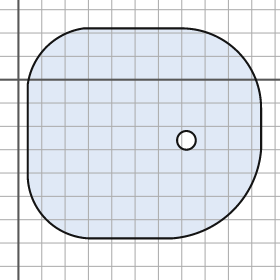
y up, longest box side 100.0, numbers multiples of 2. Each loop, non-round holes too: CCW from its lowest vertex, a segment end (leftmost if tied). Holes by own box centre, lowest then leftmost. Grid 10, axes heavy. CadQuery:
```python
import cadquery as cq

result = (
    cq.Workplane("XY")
    .moveTo(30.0, -68.0)
    .lineTo(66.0, -68.0)
    .threePointArc((92.0, -56.0), (104.0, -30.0))
    .lineTo(104.0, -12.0)
    .threePointArc((94.0, 12.0), (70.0, 22.0))
    .lineTo(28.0, 22.0)
    .threePointArc((12.0, 14.0), (4.0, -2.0))
    .lineTo(4.0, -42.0)
    .threePointArc((12.0, -60.0), (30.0, -68.0))
    .close()
    .moveTo(72.0, -26.0)
    .circle(4.0)
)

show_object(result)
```